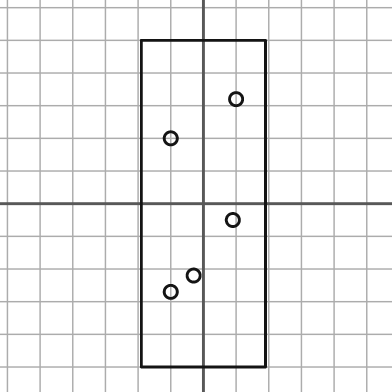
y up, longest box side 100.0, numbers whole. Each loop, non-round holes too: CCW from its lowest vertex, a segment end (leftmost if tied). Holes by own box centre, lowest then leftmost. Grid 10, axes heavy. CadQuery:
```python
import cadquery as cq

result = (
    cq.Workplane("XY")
    .moveTo(-19.0, -50.0)
    .lineTo(19.0, -50.0)
    .lineTo(19.0, 50.0)
    .lineTo(-19.0, 50.0)
    .close()
    .moveTo(-10.0, -27.0)
    .circle(2.0)
    .moveTo(-3.0, -22.0)
    .circle(2.0)
    .moveTo(9.0, -5.0)
    .circle(2.0)
    .moveTo(-10.0, 20.0)
    .circle(2.0)
    .moveTo(10.0, 32.0)
    .circle(2.0)
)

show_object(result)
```